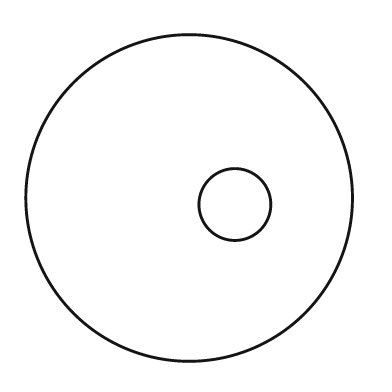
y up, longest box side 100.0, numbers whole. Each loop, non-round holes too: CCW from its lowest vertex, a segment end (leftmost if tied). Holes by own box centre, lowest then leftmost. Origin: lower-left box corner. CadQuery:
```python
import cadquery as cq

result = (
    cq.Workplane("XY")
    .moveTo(50.0, 50.0)
    .circle(50.0)
    .moveTo(64.0, 48.0)
    .circle(11.0)
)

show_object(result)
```